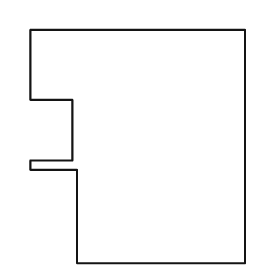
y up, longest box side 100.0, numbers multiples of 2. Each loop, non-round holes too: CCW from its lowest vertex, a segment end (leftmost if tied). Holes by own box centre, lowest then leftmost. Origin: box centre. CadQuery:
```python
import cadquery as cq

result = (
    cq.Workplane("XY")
    .moveTo(-26.0, -50.0)
    .lineTo(46.0, -50.0)
    .lineTo(46.0, 50.0)
    .lineTo(-46.0, 50.0)
    .lineTo(-46.0, 20.0)
    .lineTo(-28.0, 20.0)
    .lineTo(-28.0, -6.0)
    .lineTo(-46.0, -6.0)
    .lineTo(-46.0, -10.0)
    .lineTo(-26.0, -10.0)
    .close()
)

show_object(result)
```